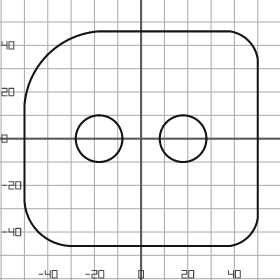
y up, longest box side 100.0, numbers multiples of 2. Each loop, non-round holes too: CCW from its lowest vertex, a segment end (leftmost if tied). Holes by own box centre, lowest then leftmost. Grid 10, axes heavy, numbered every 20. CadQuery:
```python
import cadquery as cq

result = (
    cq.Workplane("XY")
    .moveTo(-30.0, -46.0)
    .lineTo(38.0, -46.0)
    .threePointArc((46.0, -42.0), (50.0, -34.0))
    .lineTo(50.0, 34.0)
    .threePointArc((46.0, 42.0), (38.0, 46.0))
    .lineTo(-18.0, 46.0)
    .threePointArc((-40.0, 36.0), (-50.0, 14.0))
    .lineTo(-50.0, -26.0)
    .threePointArc((-44.0, -40.0), (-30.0, -46.0))
    .close()
    .moveTo(-18.0, 0.0)
    .circle(10.0)
    .moveTo(18.0, 0.0)
    .circle(10.0)
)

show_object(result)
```